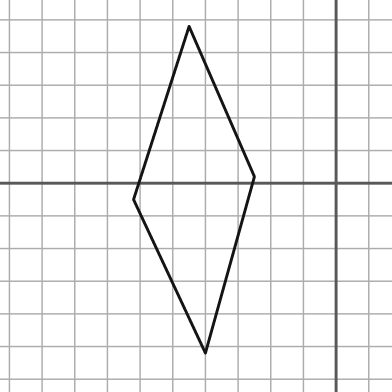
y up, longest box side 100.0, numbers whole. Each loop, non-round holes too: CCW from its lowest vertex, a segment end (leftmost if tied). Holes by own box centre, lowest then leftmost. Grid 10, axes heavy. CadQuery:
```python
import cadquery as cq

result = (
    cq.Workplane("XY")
    .moveTo(-40.0, -52.0)
    .lineTo(-25.0, 2.0)
    .lineTo(-45.0, 48.0)
    .lineTo(-62.0, -5.0)
    .close()
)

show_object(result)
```